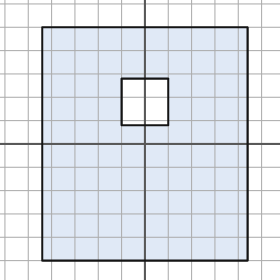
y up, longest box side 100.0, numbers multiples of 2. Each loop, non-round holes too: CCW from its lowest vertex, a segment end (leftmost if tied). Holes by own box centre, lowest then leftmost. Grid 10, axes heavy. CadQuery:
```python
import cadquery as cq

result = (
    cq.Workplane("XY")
    .moveTo(-44.0, -50.0)
    .lineTo(44.0, -50.0)
    .lineTo(44.0, 50.0)
    .lineTo(-44.0, 50.0)
    .close()
    .moveTo(-10.0, 8.0)
    .lineTo(10.0, 8.0)
    .lineTo(10.0, 28.0)
    .lineTo(-10.0, 28.0)
    .close()
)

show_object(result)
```